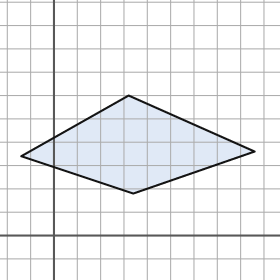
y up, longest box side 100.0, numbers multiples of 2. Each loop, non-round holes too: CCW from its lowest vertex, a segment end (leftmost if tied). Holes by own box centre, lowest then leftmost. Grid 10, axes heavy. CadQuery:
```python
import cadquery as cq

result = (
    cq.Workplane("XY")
    .moveTo(34.0, 18.0)
    .lineTo(86.0, 36.0)
    .lineTo(32.0, 60.0)
    .lineTo(-14.0, 34.0)
    .close()
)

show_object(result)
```